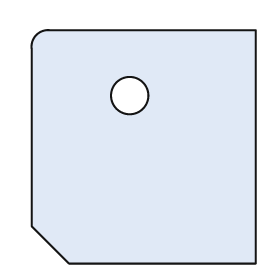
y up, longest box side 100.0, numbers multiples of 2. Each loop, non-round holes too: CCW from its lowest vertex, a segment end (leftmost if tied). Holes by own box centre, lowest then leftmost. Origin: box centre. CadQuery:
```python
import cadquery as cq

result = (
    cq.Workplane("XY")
    .moveTo(-32.0, -50.0)
    .lineTo(48.0, -50.0)
    .lineTo(48.0, 50.0)
    .lineTo(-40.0, 50.0)
    .threePointArc((-46.0, 48.0), (-48.0, 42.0))
    .lineTo(-48.0, -34.0)
    .close()
    .moveTo(-6.0, 22.0)
    .circle(8.0)
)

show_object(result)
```